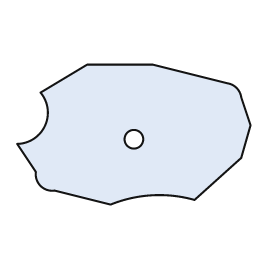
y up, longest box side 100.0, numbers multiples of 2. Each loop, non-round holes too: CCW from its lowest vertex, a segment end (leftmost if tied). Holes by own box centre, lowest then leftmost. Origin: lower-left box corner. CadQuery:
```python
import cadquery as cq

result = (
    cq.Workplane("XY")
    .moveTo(40.0, 0.0)
    .threePointArc((58.0, 4.0), (76.0, 2.0))
    .lineTo(96.0, 20.0)
    .lineTo(100.0, 34.0)
    .lineTo(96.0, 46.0)
    .threePointArc((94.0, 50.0), (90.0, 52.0))
    .lineTo(58.0, 60.0)
    .lineTo(30.0, 60.0)
    .lineTo(10.0, 48.0)
    .threePointArc((12.0, 34.0), (0.0, 26.0))
    .lineTo(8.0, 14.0)
    .threePointArc((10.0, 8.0), (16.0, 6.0))
    .close()
    .moveTo(50.0, 28.0)
    .circle(4.0)
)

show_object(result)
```